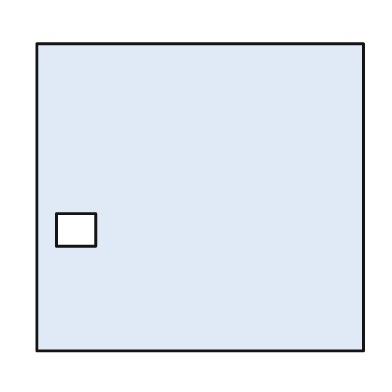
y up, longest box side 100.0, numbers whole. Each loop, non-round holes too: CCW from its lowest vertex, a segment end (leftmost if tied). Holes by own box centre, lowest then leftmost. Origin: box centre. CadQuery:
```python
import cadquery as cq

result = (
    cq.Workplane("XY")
    .moveTo(-50.0, -47.0)
    .lineTo(50.0, -47.0)
    .lineTo(50.0, 47.0)
    .lineTo(-50.0, 47.0)
    .close()
    .moveTo(-44.0, -15.0)
    .lineTo(-32.0, -15.0)
    .lineTo(-32.0, -5.0)
    .lineTo(-44.0, -5.0)
    .close()
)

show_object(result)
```